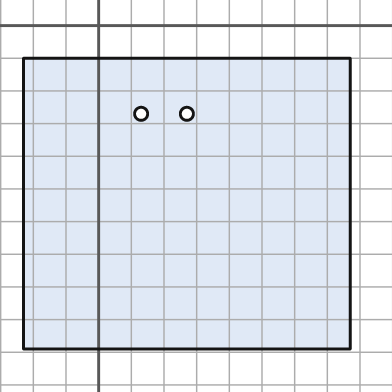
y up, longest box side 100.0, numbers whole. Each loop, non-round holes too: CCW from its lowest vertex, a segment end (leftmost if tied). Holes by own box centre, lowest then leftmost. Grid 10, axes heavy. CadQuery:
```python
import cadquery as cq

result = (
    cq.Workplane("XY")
    .moveTo(-23.0, -99.0)
    .lineTo(77.0, -99.0)
    .lineTo(77.0, -10.0)
    .lineTo(-23.0, -10.0)
    .close()
    .moveTo(13.0, -27.0)
    .circle(2.0)
    .moveTo(27.0, -27.0)
    .circle(2.0)
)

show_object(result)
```